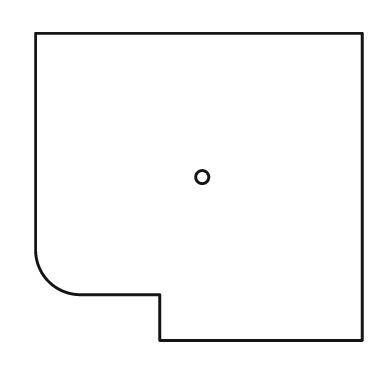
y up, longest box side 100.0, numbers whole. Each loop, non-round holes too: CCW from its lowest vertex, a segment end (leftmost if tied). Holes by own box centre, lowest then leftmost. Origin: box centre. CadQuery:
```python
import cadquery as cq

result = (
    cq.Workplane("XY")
    .moveTo(-12.0, -47.0)
    .lineTo(50.0, -47.0)
    .lineTo(50.0, 47.0)
    .lineTo(-50.0, 47.0)
    .lineTo(-50.0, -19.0)
    .threePointArc((-46.0, -29.0), (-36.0, -33.0))
    .lineTo(-12.0, -33.0)
    .close()
    .moveTo(1.0, 3.0)
    .circle(2.0)
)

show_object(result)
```